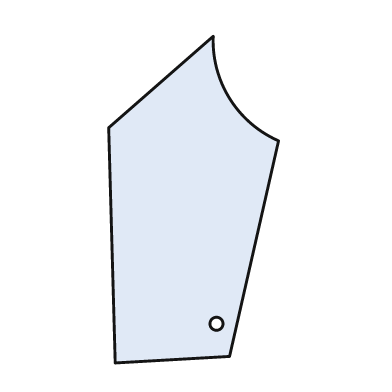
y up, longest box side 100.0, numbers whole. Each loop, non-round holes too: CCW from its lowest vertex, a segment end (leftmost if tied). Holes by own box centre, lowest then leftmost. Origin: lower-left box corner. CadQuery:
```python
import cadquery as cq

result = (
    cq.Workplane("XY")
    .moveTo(2.0, 0.0)
    .lineTo(37.0, 2.0)
    .lineTo(52.0, 68.0)
    .threePointArc((37.0, 81.0), (32.0, 100.0))
    .lineTo(0.0, 72.0)
    .close()
    .moveTo(33.0, 12.0)
    .circle(2.0)
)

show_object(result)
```